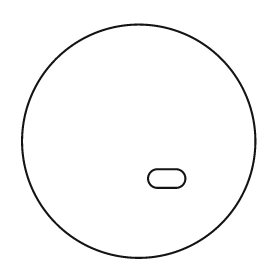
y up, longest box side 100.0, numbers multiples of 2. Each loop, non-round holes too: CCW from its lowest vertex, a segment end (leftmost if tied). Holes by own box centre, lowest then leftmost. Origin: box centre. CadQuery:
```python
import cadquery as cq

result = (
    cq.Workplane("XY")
    .moveTo(0.0, 0.0)
    .circle(50.0)
    .moveTo(8.0, -20.0)
    .lineTo(16.0, -20.0)
    .threePointArc((20.0, -16.0), (16.0, -12.0))
    .lineTo(8.0, -12.0)
    .threePointArc((4.0, -16.0), (8.0, -20.0))
    .close()
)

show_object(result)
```